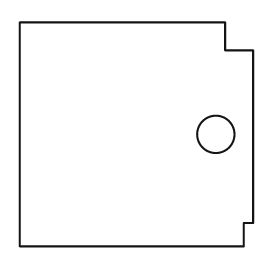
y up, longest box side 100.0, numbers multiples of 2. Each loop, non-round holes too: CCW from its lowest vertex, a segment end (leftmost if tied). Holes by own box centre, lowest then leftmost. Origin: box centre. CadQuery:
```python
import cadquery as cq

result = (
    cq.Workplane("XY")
    .moveTo(-50.0, -48.0)
    .lineTo(46.0, -48.0)
    .lineTo(46.0, -38.0)
    .lineTo(50.0, -38.0)
    .lineTo(50.0, 36.0)
    .lineTo(38.0, 36.0)
    .lineTo(38.0, 48.0)
    .lineTo(-50.0, 48.0)
    .close()
    .moveTo(34.0, 0.0)
    .circle(8.0)
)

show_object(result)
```